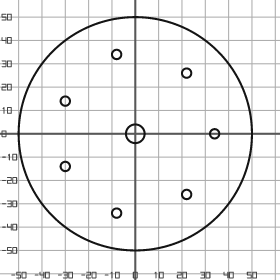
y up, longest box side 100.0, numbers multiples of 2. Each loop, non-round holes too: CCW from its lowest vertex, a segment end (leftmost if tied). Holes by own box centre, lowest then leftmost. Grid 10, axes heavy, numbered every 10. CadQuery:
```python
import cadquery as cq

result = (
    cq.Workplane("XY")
    .moveTo(0.0, 0.0)
    .circle(50.0)
    .moveTo(-8.0, -34.0)
    .circle(2.0)
    .moveTo(22.0, -26.0)
    .circle(2.0)
    .moveTo(-30.0, -14.0)
    .circle(2.0)
    .moveTo(0.0, 0.0)
    .circle(4.0)
    .moveTo(34.0, 0.0)
    .circle(2.0)
    .moveTo(-30.0, 14.0)
    .circle(2.0)
    .moveTo(22.0, 26.0)
    .circle(2.0)
    .moveTo(-8.0, 34.0)
    .circle(2.0)
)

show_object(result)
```